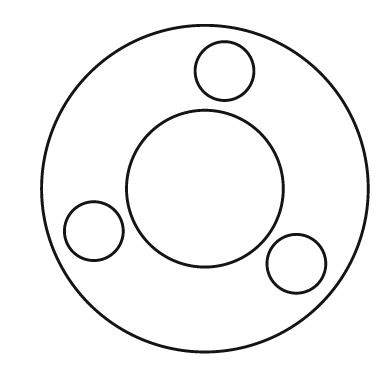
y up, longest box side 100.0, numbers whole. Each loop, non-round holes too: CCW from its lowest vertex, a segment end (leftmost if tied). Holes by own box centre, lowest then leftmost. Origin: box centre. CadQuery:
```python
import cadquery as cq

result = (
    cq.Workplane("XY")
    .moveTo(0.0, 0.0)
    .circle(50.0)
    .moveTo(28.0, -23.0)
    .circle(9.0)
    .moveTo(-34.0, -13.0)
    .circle(9.0)
    .moveTo(0.0, 0.0)
    .circle(24.0)
    .moveTo(6.0, 36.0)
    .circle(9.0)
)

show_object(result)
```